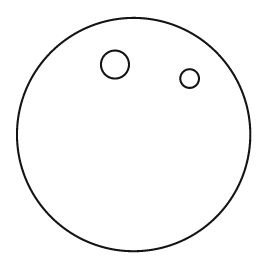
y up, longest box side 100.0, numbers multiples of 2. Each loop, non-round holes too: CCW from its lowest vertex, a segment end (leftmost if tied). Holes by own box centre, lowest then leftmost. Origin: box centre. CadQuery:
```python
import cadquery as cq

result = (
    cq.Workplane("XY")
    .moveTo(0.0, 0.0)
    .circle(50.0)
    .moveTo(24.0, 24.0)
    .circle(4.0)
    .moveTo(-8.0, 30.0)
    .circle(6.0)
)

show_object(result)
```